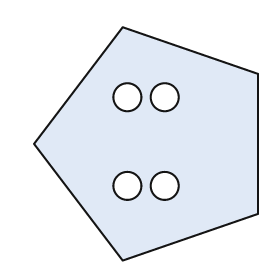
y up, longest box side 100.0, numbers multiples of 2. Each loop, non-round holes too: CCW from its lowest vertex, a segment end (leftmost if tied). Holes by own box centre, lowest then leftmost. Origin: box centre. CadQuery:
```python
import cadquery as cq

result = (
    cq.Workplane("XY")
    .moveTo(-10.0, -50.0)
    .lineTo(48.0, -30.0)
    .lineTo(48.0, 30.0)
    .lineTo(-10.0, 50.0)
    .lineTo(-48.0, 0.0)
    .close()
    .moveTo(-8.0, -18.0)
    .circle(6.0)
    .moveTo(8.0, -18.0)
    .circle(6.0)
    .moveTo(-8.0, 20.0)
    .circle(6.0)
    .moveTo(8.0, 20.0)
    .circle(6.0)
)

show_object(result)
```